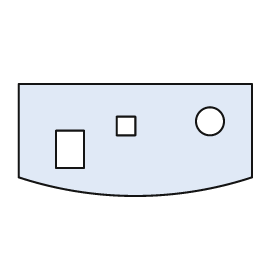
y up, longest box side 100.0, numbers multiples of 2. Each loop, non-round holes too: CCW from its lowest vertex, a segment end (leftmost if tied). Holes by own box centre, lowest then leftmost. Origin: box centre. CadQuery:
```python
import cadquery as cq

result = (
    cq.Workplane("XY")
    .moveTo(-50.0, -16.0)
    .threePointArc((0.0, -24.0), (50.0, -16.0))
    .lineTo(50.0, 24.0)
    .lineTo(-50.0, 24.0)
    .close()
    .moveTo(-34.0, -12.0)
    .lineTo(-22.0, -12.0)
    .lineTo(-22.0, 4.0)
    .lineTo(-34.0, 4.0)
    .close()
    .moveTo(-8.0, 2.0)
    .lineTo(0.0, 2.0)
    .lineTo(0.0, 10.0)
    .lineTo(-8.0, 10.0)
    .close()
    .moveTo(32.0, 8.0)
    .circle(6.0)
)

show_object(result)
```